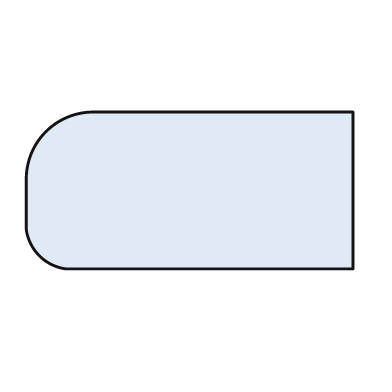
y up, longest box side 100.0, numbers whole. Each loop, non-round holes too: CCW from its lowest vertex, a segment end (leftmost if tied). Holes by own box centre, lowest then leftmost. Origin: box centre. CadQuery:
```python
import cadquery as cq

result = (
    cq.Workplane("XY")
    .moveTo(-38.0, -24.0)
    .lineTo(50.0, -24.0)
    .lineTo(50.0, 24.0)
    .lineTo(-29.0, 24.0)
    .threePointArc((-44.0, 18.0), (-50.0, 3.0))
    .lineTo(-50.0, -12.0)
    .threePointArc((-46.0, -20.0), (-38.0, -24.0))
    .close()
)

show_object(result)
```